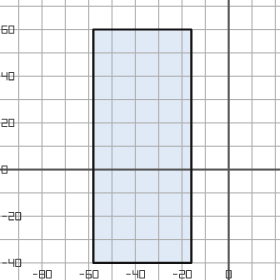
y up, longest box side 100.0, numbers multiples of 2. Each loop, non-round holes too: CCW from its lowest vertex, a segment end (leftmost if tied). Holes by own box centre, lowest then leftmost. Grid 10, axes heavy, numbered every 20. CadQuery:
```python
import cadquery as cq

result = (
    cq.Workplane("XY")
    .moveTo(-58.0, -40.0)
    .lineTo(-16.0, -40.0)
    .lineTo(-16.0, 60.0)
    .lineTo(-58.0, 60.0)
    .close()
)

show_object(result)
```